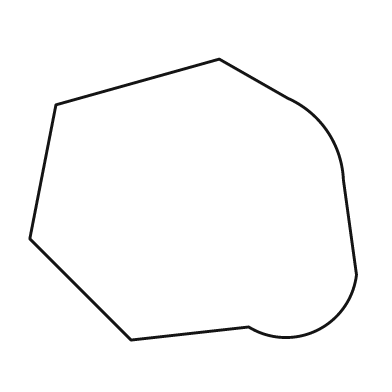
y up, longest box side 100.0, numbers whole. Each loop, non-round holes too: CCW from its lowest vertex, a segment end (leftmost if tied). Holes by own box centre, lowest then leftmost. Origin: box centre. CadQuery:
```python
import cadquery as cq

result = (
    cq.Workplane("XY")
    .moveTo(-19.0, -43.0)
    .lineTo(17.0, -39.0)
    .threePointArc((38.0, -40.0), (50.0, -23.0))
    .lineTo(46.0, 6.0)
    .threePointArc((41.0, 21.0), (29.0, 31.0))
    .lineTo(8.0, 43.0)
    .lineTo(-42.0, 29.0)
    .lineTo(-50.0, -12.0)
    .close()
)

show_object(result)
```